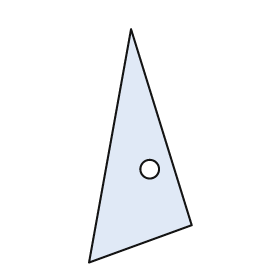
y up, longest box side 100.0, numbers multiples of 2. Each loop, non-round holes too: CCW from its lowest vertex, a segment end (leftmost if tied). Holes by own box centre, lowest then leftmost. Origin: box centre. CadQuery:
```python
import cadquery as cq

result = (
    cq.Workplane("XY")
    .moveTo(-22.0, -50.0)
    .lineTo(22.0, -34.0)
    .lineTo(-4.0, 50.0)
    .close()
    .moveTo(4.0, -10.0)
    .circle(4.0)
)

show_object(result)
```